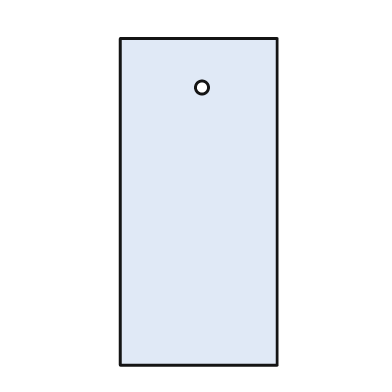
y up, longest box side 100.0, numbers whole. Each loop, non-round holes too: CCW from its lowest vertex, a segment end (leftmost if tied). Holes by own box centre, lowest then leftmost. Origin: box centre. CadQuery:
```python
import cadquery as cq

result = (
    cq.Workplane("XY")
    .moveTo(-24.0, -50.0)
    .lineTo(24.0, -50.0)
    .lineTo(24.0, 50.0)
    .lineTo(-24.0, 50.0)
    .close()
    .moveTo(1.0, 35.0)
    .circle(2.0)
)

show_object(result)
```